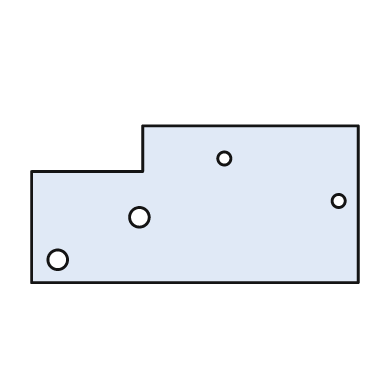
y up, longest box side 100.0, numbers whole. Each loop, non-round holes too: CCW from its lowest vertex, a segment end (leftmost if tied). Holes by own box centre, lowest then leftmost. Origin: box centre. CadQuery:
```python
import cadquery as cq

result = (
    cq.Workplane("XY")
    .moveTo(-50.0, -24.0)
    .lineTo(50.0, -24.0)
    .lineTo(50.0, 24.0)
    .lineTo(-16.0, 24.0)
    .lineTo(-16.0, 10.0)
    .lineTo(-50.0, 10.0)
    .close()
    .moveTo(-42.0, -17.0)
    .circle(3.0)
    .moveTo(-17.0, -4.0)
    .circle(3.0)
    .moveTo(44.0, 1.0)
    .circle(2.0)
    .moveTo(9.0, 14.0)
    .circle(2.0)
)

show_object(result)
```